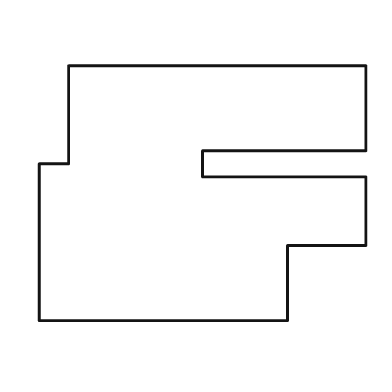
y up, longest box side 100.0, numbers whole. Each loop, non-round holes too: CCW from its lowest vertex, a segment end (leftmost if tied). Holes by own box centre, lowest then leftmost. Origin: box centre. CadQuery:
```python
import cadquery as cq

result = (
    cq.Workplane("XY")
    .moveTo(-50.0, -39.0)
    .lineTo(26.0, -39.0)
    .lineTo(26.0, -16.0)
    .lineTo(50.0, -16.0)
    .lineTo(50.0, 5.0)
    .lineTo(0.0, 5.0)
    .lineTo(0.0, 13.0)
    .lineTo(50.0, 13.0)
    .lineTo(50.0, 39.0)
    .lineTo(-41.0, 39.0)
    .lineTo(-41.0, 9.0)
    .lineTo(-50.0, 9.0)
    .close()
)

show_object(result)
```